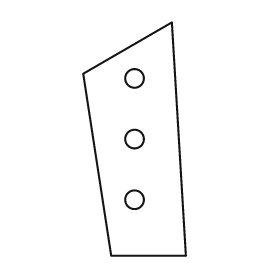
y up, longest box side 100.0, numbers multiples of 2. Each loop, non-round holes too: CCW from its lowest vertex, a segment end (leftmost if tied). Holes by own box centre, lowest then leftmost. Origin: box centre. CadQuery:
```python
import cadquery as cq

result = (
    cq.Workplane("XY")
    .moveTo(-10.0, -50.0)
    .lineTo(22.0, -50.0)
    .lineTo(16.0, 50.0)
    .lineTo(-22.0, 28.0)
    .close()
    .moveTo(0.0, -26.0)
    .circle(4.0)
    .moveTo(0.0, 0.0)
    .circle(4.0)
    .moveTo(0.0, 26.0)
    .circle(4.0)
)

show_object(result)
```